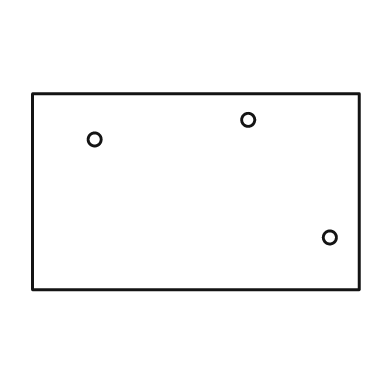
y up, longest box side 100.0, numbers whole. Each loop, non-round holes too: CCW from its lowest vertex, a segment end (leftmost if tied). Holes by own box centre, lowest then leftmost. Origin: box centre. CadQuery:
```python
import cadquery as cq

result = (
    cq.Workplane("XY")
    .moveTo(-50.0, -30.0)
    .lineTo(50.0, -30.0)
    .lineTo(50.0, 30.0)
    .lineTo(-50.0, 30.0)
    .close()
    .moveTo(41.0, -14.0)
    .circle(2.0)
    .moveTo(-31.0, 16.0)
    .circle(2.0)
    .moveTo(16.0, 22.0)
    .circle(2.0)
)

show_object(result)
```